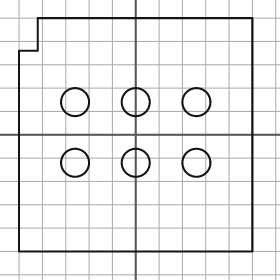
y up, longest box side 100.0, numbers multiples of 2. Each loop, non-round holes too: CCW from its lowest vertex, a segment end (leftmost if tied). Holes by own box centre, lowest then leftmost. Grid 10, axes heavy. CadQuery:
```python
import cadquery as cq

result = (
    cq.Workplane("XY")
    .moveTo(-50.0, -50.0)
    .lineTo(50.0, -50.0)
    .lineTo(50.0, 50.0)
    .lineTo(-42.0, 50.0)
    .lineTo(-42.0, 36.0)
    .lineTo(-50.0, 36.0)
    .close()
    .moveTo(-26.0, -12.0)
    .circle(6.0)
    .moveTo(0.0, -12.0)
    .circle(6.0)
    .moveTo(26.0, -12.0)
    .circle(6.0)
    .moveTo(-26.0, 14.0)
    .circle(6.0)
    .moveTo(0.0, 14.0)
    .circle(6.0)
    .moveTo(26.0, 14.0)
    .circle(6.0)
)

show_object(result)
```